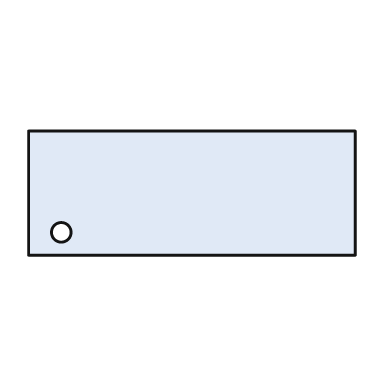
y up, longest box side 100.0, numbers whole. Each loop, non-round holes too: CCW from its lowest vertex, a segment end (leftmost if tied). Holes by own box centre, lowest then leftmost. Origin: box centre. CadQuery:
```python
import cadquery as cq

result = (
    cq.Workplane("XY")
    .moveTo(-50.0, -19.0)
    .lineTo(50.0, -19.0)
    .lineTo(50.0, 19.0)
    .lineTo(-50.0, 19.0)
    .close()
    .moveTo(-40.0, -12.0)
    .circle(3.0)
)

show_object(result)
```